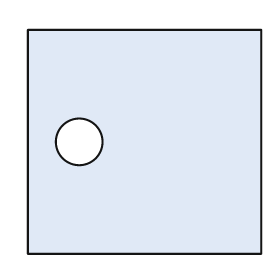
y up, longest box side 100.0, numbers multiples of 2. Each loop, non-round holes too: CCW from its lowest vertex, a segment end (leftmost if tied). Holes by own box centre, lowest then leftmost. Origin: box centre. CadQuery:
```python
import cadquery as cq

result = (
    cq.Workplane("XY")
    .moveTo(-50.0, -48.0)
    .lineTo(50.0, -48.0)
    .lineTo(50.0, 48.0)
    .lineTo(-50.0, 48.0)
    .close()
    .moveTo(-28.0, 0.0)
    .circle(10.0)
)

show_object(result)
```